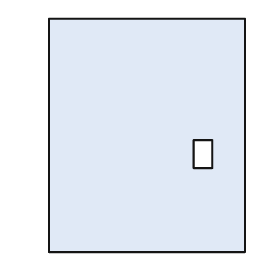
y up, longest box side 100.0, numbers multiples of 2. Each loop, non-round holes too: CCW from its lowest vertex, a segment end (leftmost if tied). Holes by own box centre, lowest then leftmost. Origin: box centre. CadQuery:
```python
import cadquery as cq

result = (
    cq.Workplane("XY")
    .moveTo(-42.0, -50.0)
    .lineTo(42.0, -50.0)
    .lineTo(42.0, 50.0)
    .lineTo(-42.0, 50.0)
    .close()
    .moveTo(20.0, -14.0)
    .lineTo(28.0, -14.0)
    .lineTo(28.0, -2.0)
    .lineTo(20.0, -2.0)
    .close()
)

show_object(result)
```